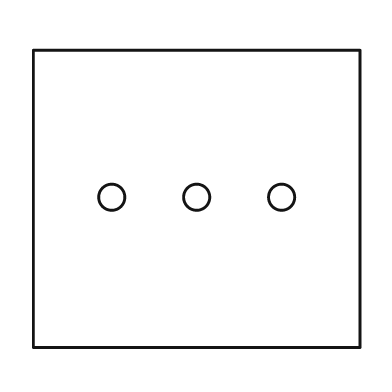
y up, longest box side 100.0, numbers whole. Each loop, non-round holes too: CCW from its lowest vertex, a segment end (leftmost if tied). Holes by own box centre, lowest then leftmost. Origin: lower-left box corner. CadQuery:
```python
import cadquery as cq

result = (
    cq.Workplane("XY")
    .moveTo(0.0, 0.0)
    .lineTo(100.0, 0.0)
    .lineTo(100.0, 91.0)
    .lineTo(0.0, 91.0)
    .close()
    .moveTo(24.0, 46.0)
    .circle(4.0)
    .moveTo(50.0, 46.0)
    .circle(4.0)
    .moveTo(76.0, 46.0)
    .circle(4.0)
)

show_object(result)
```